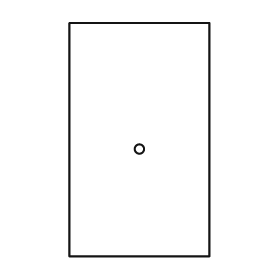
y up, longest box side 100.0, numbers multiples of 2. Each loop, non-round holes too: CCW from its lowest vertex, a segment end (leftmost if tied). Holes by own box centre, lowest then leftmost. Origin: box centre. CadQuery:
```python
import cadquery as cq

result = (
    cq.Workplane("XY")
    .moveTo(-30.0, -50.0)
    .lineTo(30.0, -50.0)
    .lineTo(30.0, 50.0)
    .lineTo(-30.0, 50.0)
    .close()
    .moveTo(0.0, -4.0)
    .circle(2.0)
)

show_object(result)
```